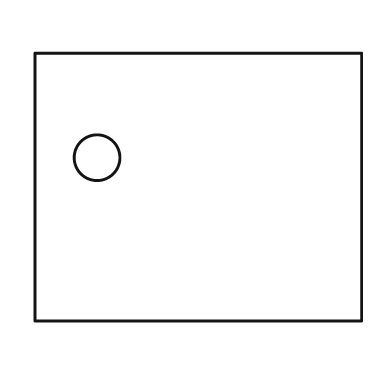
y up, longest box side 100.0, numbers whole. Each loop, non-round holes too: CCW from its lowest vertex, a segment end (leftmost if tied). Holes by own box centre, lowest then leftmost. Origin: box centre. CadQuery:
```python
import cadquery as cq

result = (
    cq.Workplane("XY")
    .moveTo(-50.0, -41.0)
    .lineTo(50.0, -41.0)
    .lineTo(50.0, 41.0)
    .lineTo(-50.0, 41.0)
    .close()
    .moveTo(-31.0, 9.0)
    .circle(7.0)
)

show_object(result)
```